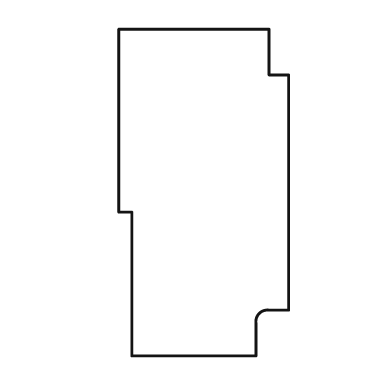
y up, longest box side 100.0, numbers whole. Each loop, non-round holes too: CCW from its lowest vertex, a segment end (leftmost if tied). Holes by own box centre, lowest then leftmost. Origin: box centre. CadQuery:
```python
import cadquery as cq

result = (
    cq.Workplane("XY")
    .moveTo(-22.0, -50.0)
    .lineTo(16.0, -50.0)
    .lineTo(16.0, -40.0)
    .threePointArc((17.0, -37.0), (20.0, -36.0))
    .lineTo(26.0, -36.0)
    .lineTo(26.0, 36.0)
    .lineTo(20.0, 36.0)
    .lineTo(20.0, 50.0)
    .lineTo(-26.0, 50.0)
    .lineTo(-26.0, -6.0)
    .lineTo(-22.0, -6.0)
    .close()
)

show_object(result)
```